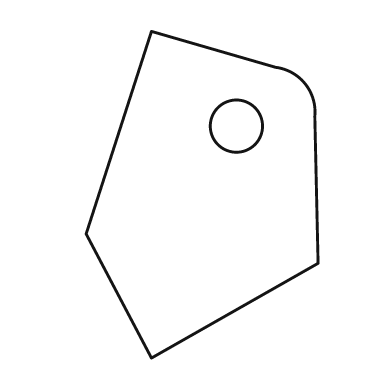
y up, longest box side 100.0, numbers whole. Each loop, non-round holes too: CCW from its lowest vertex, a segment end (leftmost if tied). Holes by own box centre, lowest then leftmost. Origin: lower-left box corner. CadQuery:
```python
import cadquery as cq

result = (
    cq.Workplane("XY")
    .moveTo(20.0, 0.0)
    .lineTo(71.0, 29.0)
    .lineTo(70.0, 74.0)
    .threePointArc((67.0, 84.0), (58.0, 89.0))
    .lineTo(20.0, 100.0)
    .lineTo(0.0, 38.0)
    .close()
    .moveTo(46.0, 71.0)
    .circle(8.0)
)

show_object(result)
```